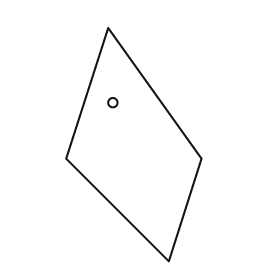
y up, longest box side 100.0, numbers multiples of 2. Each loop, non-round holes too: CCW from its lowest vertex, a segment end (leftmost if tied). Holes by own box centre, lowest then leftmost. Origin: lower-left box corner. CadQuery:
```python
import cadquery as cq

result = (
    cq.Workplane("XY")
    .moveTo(44.0, 0.0)
    .lineTo(58.0, 44.0)
    .lineTo(18.0, 100.0)
    .lineTo(0.0, 44.0)
    .close()
    .moveTo(20.0, 68.0)
    .circle(2.0)
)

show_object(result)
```